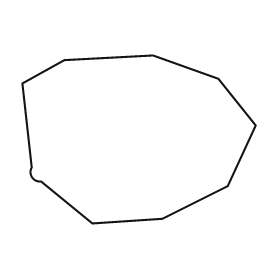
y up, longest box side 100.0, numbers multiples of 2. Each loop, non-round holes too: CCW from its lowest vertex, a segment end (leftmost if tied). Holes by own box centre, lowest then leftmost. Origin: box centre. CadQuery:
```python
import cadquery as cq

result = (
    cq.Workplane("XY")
    .moveTo(-20.0, -36.0)
    .lineTo(10.0, -34.0)
    .lineTo(38.0, -20.0)
    .lineTo(50.0, 6.0)
    .lineTo(34.0, 26.0)
    .lineTo(6.0, 36.0)
    .lineTo(-32.0, 34.0)
    .lineTo(-50.0, 24.0)
    .lineTo(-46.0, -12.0)
    .threePointArc((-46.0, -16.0), (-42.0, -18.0))
    .close()
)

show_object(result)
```